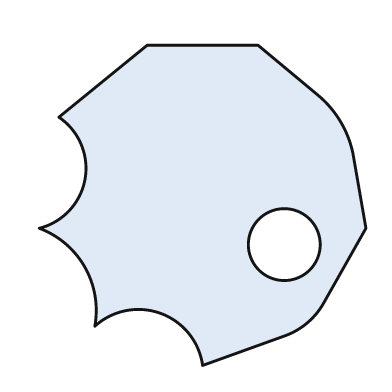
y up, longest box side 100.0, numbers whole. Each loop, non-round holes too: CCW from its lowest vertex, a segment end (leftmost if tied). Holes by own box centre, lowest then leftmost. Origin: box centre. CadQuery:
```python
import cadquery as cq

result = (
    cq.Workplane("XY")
    .moveTo(0.0, -49.0)
    .lineTo(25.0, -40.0)
    .threePointArc((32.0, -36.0), (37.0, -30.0))
    .lineTo(50.0, -7.0)
    .lineTo(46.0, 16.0)
    .threePointArc((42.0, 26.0), (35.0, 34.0))
    .lineTo(17.0, 49.0)
    .lineTo(-17.0, 49.0)
    .lineTo(-44.0, 27.0)
    .threePointArc((-36.0, 8.0), (-50.0, -7.0))
    .threePointArc((-36.0, -19.0), (-33.0, -37.0))
    .threePointArc((-13.0, -33.0), (0.0, -49.0))
    .close()
    .moveTo(25.0, -12.0)
    .circle(11.0)
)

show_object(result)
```